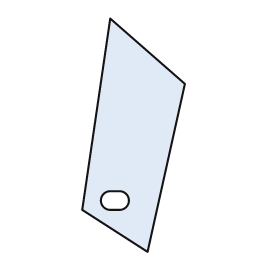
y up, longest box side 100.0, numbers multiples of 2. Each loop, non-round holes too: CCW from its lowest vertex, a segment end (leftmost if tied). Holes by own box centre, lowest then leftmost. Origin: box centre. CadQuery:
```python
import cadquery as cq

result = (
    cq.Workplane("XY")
    .moveTo(6.0, -50.0)
    .lineTo(22.0, 22.0)
    .lineTo(-10.0, 50.0)
    .lineTo(-22.0, -32.0)
    .close()
    .moveTo(-10.0, -32.0)
    .lineTo(-6.0, -32.0)
    .threePointArc((-2.0, -28.0), (-6.0, -24.0))
    .lineTo(-10.0, -24.0)
    .threePointArc((-14.0, -28.0), (-10.0, -32.0))
    .close()
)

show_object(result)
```